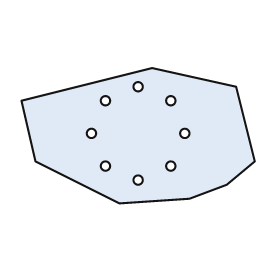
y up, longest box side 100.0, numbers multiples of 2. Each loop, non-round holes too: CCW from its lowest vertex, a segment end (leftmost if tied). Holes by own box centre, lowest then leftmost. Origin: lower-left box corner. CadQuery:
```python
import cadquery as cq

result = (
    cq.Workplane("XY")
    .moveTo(42.0, 0.0)
    .lineTo(72.0, 2.0)
    .lineTo(88.0, 8.0)
    .lineTo(100.0, 18.0)
    .lineTo(92.0, 50.0)
    .lineTo(56.0, 58.0)
    .lineTo(0.0, 44.0)
    .lineTo(6.0, 18.0)
    .close()
    .moveTo(50.0, 10.0)
    .circle(2.0)
    .moveTo(36.0, 16.0)
    .circle(2.0)
    .moveTo(64.0, 16.0)
    .circle(2.0)
    .moveTo(30.0, 30.0)
    .circle(2.0)
    .moveTo(70.0, 30.0)
    .circle(2.0)
    .moveTo(36.0, 44.0)
    .circle(2.0)
    .moveTo(64.0, 44.0)
    .circle(2.0)
    .moveTo(50.0, 50.0)
    .circle(2.0)
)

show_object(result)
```